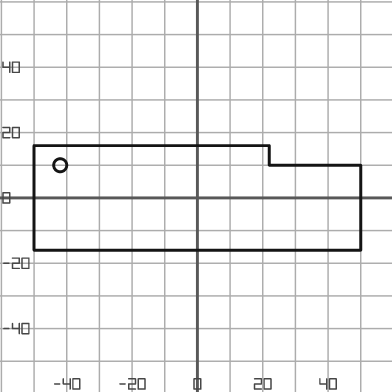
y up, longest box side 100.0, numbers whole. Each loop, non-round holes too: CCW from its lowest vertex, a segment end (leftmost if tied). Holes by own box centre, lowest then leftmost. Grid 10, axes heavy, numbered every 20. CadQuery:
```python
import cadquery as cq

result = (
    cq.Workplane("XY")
    .moveTo(-50.0, -16.0)
    .lineTo(50.0, -16.0)
    .lineTo(50.0, 10.0)
    .lineTo(22.0, 10.0)
    .lineTo(22.0, 16.0)
    .lineTo(-50.0, 16.0)
    .close()
    .moveTo(-42.0, 10.0)
    .circle(2.0)
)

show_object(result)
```